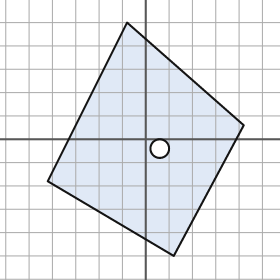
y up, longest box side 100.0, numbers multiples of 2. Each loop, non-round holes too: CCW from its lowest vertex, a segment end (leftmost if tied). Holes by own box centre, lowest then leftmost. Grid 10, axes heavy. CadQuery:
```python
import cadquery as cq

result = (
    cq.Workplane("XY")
    .moveTo(12.0, -50.0)
    .lineTo(42.0, 6.0)
    .lineTo(-8.0, 50.0)
    .lineTo(-42.0, -18.0)
    .close()
    .moveTo(6.0, -4.0)
    .circle(4.0)
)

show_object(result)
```